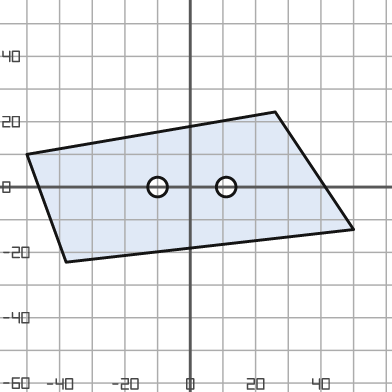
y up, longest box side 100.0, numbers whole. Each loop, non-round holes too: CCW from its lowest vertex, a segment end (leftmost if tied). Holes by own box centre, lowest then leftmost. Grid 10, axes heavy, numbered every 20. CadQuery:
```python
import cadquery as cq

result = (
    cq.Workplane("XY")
    .moveTo(-38.0, -23.0)
    .lineTo(50.0, -13.0)
    .lineTo(26.0, 23.0)
    .lineTo(-50.0, 10.0)
    .close()
    .moveTo(-10.0, 0.0)
    .circle(3.0)
    .moveTo(11.0, 0.0)
    .circle(3.0)
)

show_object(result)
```